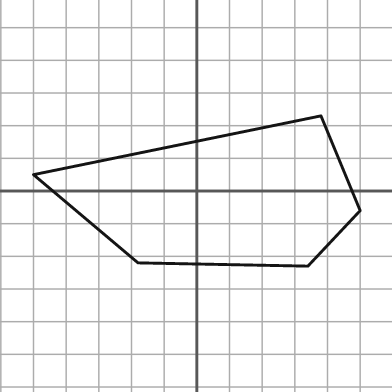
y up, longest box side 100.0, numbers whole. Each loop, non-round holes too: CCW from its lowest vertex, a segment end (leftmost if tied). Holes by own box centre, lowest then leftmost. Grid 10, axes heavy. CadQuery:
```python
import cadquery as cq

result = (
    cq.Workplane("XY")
    .moveTo(34.0, -23.0)
    .lineTo(50.0, -6.0)
    .lineTo(38.0, 23.0)
    .lineTo(-50.0, 5.0)
    .lineTo(-18.0, -22.0)
    .close()
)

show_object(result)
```